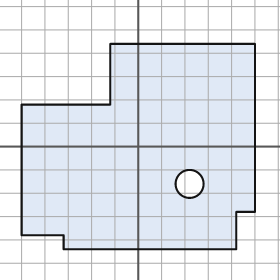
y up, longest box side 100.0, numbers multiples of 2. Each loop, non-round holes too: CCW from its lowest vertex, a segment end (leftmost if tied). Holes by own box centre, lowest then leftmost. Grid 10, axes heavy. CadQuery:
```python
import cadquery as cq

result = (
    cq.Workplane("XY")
    .moveTo(-32.0, -44.0)
    .lineTo(42.0, -44.0)
    .lineTo(42.0, -28.0)
    .lineTo(50.0, -28.0)
    .lineTo(50.0, 44.0)
    .lineTo(-12.0, 44.0)
    .lineTo(-12.0, 18.0)
    .lineTo(-50.0, 18.0)
    .lineTo(-50.0, -38.0)
    .lineTo(-32.0, -38.0)
    .close()
    .moveTo(22.0, -16.0)
    .circle(6.0)
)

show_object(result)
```